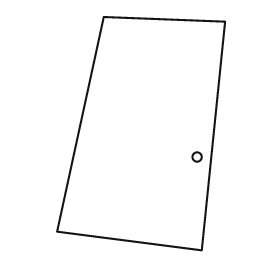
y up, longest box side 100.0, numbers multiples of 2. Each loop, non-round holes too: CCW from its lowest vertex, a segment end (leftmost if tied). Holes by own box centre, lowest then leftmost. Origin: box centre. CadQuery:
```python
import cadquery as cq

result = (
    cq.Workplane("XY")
    .moveTo(26.0, -50.0)
    .lineTo(36.0, 48.0)
    .lineTo(-16.0, 50.0)
    .lineTo(-36.0, -42.0)
    .close()
    .moveTo(24.0, -10.0)
    .circle(2.0)
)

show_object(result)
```